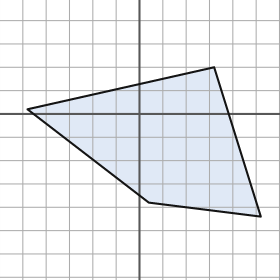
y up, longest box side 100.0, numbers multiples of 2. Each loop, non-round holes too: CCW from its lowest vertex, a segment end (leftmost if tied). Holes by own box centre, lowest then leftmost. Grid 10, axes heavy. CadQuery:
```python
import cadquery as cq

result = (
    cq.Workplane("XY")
    .moveTo(52.0, -44.0)
    .lineTo(32.0, 20.0)
    .lineTo(-48.0, 2.0)
    .lineTo(4.0, -38.0)
    .close()
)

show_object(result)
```